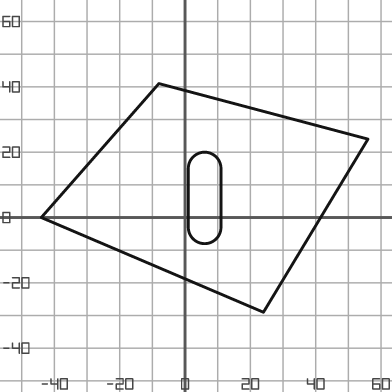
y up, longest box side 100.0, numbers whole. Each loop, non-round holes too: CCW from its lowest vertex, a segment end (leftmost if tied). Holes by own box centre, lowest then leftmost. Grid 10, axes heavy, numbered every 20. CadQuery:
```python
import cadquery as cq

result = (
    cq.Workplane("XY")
    .moveTo(24.0, -29.0)
    .lineTo(56.0, 24.0)
    .lineTo(-8.0, 41.0)
    .lineTo(-44.0, 0.0)
    .close()
    .moveTo(1.0, -3.0)
    .threePointArc((6.0, -8.0), (11.0, -3.0))
    .lineTo(11.0, 15.0)
    .threePointArc((6.0, 20.0), (1.0, 15.0))
    .close()
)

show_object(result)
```